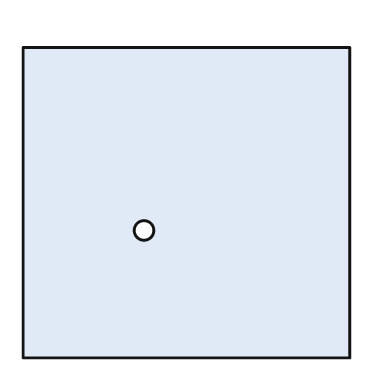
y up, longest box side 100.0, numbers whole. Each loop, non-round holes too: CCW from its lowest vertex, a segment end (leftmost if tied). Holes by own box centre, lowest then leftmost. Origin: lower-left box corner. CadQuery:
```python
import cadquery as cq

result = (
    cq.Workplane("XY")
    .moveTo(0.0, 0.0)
    .lineTo(100.0, 0.0)
    .lineTo(100.0, 95.0)
    .lineTo(0.0, 95.0)
    .close()
    .moveTo(37.0, 39.0)
    .circle(3.0)
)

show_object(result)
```